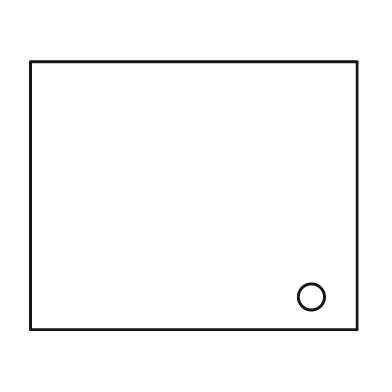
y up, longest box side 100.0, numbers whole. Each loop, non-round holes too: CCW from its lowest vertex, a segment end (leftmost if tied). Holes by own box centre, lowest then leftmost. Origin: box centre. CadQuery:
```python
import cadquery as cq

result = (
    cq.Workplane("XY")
    .moveTo(-50.0, -41.0)
    .lineTo(50.0, -41.0)
    .lineTo(50.0, 41.0)
    .lineTo(-50.0, 41.0)
    .close()
    .moveTo(36.0, -31.0)
    .circle(4.0)
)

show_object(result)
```